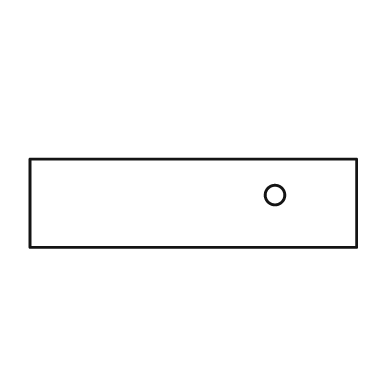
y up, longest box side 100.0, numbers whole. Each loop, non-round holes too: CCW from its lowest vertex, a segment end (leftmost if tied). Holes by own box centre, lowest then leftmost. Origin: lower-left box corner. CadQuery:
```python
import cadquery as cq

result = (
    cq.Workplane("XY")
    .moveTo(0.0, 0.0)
    .lineTo(100.0, 0.0)
    .lineTo(100.0, 27.0)
    .lineTo(0.0, 27.0)
    .close()
    .moveTo(75.0, 16.0)
    .circle(3.0)
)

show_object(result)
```